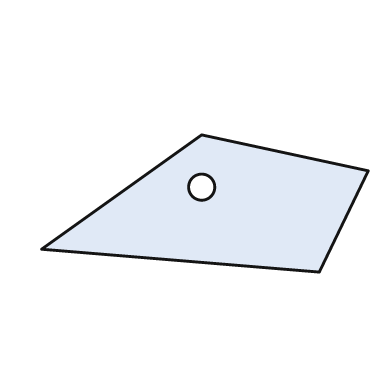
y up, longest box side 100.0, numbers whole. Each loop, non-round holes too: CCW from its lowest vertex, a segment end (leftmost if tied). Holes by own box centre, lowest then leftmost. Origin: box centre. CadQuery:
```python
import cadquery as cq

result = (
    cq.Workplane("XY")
    .moveTo(35.0, -21.0)
    .lineTo(50.0, 10.0)
    .lineTo(-1.0, 21.0)
    .lineTo(-50.0, -14.0)
    .close()
    .moveTo(-1.0, 5.0)
    .circle(4.0)
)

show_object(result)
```